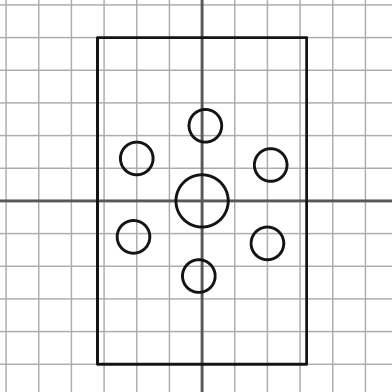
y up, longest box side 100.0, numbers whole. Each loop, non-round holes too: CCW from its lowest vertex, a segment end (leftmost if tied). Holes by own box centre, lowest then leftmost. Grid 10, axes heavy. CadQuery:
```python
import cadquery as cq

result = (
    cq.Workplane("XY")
    .moveTo(-32.0, -50.0)
    .lineTo(32.0, -50.0)
    .lineTo(32.0, 50.0)
    .lineTo(-32.0, 50.0)
    .close()
    .moveTo(-1.0, -23.0)
    .circle(5.0)
    .moveTo(20.0, -13.0)
    .circle(5.0)
    .moveTo(-21.0, -11.0)
    .circle(5.0)
    .moveTo(0.0, 0.0)
    .circle(8.0)
    .moveTo(21.0, 11.0)
    .circle(5.0)
    .moveTo(-20.0, 13.0)
    .circle(5.0)
    .moveTo(1.0, 23.0)
    .circle(5.0)
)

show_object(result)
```